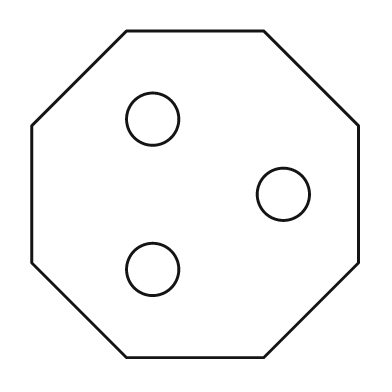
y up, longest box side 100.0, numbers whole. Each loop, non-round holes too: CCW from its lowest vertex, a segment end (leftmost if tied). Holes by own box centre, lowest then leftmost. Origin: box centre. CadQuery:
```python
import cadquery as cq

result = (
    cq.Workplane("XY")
    .moveTo(-21.0, -50.0)
    .lineTo(21.0, -50.0)
    .lineTo(50.0, -21.0)
    .lineTo(50.0, 21.0)
    .lineTo(21.0, 50.0)
    .lineTo(-21.0, 50.0)
    .lineTo(-50.0, 21.0)
    .lineTo(-50.0, -21.0)
    .close()
    .moveTo(-13.0, -23.0)
    .circle(8.0)
    .moveTo(27.0, 0.0)
    .circle(8.0)
    .moveTo(-13.0, 23.0)
    .circle(8.0)
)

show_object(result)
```